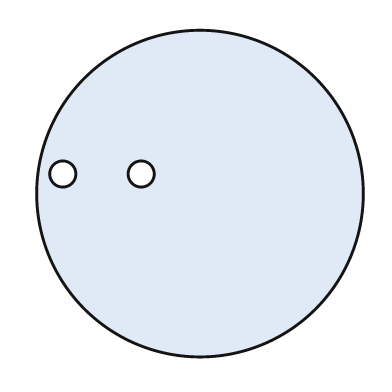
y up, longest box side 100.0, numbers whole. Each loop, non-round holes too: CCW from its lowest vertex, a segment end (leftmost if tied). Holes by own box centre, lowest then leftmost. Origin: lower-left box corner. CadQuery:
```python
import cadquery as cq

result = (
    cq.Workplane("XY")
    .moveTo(50.0, 50.0)
    .circle(50.0)
    .moveTo(8.0, 56.0)
    .circle(4.0)
    .moveTo(32.0, 56.0)
    .circle(4.0)
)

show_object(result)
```